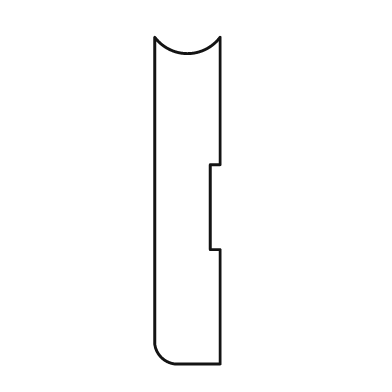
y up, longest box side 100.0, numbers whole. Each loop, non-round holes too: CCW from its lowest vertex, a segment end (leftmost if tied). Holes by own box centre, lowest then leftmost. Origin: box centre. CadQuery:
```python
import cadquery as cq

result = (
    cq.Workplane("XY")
    .moveTo(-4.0, -50.0)
    .lineTo(10.0, -50.0)
    .lineTo(10.0, -15.0)
    .lineTo(7.0, -15.0)
    .lineTo(7.0, 11.0)
    .lineTo(10.0, 11.0)
    .lineTo(10.0, 50.0)
    .threePointArc((0.0, 45.0), (-10.0, 50.0))
    .lineTo(-10.0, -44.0)
    .threePointArc((-8.0, -48.0), (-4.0, -50.0))
    .close()
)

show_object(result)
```